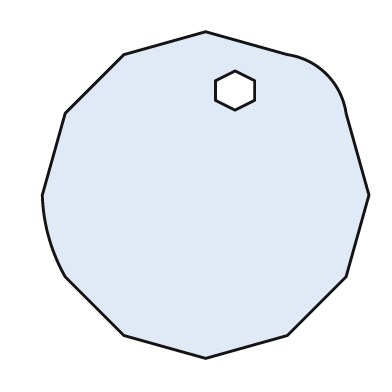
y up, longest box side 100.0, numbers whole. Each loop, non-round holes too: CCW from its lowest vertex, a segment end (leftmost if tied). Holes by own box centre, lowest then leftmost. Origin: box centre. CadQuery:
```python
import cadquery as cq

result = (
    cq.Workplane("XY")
    .moveTo(0.0, -50.0)
    .lineTo(25.0, -43.0)
    .lineTo(43.0, -25.0)
    .lineTo(50.0, 0.0)
    .lineTo(43.0, 25.0)
    .threePointArc((37.0, 37.0), (25.0, 43.0))
    .lineTo(0.0, 50.0)
    .lineTo(-25.0, 43.0)
    .lineTo(-43.0, 25.0)
    .lineTo(-50.0, 0.0)
    .threePointArc((-48.0, -13.0), (-43.0, -25.0))
    .lineTo(-25.0, -43.0)
    .close()
    .moveTo(9.0, 26.0)
    .lineTo(15.0, 29.0)
    .lineTo(15.0, 35.0)
    .lineTo(9.0, 38.0)
    .lineTo(3.0, 35.0)
    .lineTo(3.0, 29.0)
    .close()
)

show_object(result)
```